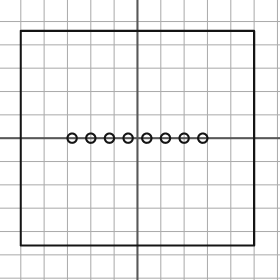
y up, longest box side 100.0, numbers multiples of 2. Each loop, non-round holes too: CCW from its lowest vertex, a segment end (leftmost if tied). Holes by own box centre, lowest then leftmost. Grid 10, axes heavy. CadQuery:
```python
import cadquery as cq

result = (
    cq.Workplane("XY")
    .moveTo(-50.0, -46.0)
    .lineTo(50.0, -46.0)
    .lineTo(50.0, 46.0)
    .lineTo(-50.0, 46.0)
    .close()
    .moveTo(-28.0, 0.0)
    .circle(2.0)
    .moveTo(-20.0, 0.0)
    .circle(2.0)
    .moveTo(-12.0, 0.0)
    .circle(2.0)
    .moveTo(-4.0, 0.0)
    .circle(2.0)
    .moveTo(4.0, 0.0)
    .circle(2.0)
    .moveTo(12.0, 0.0)
    .circle(2.0)
    .moveTo(20.0, 0.0)
    .circle(2.0)
    .moveTo(28.0, 0.0)
    .circle(2.0)
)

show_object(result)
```